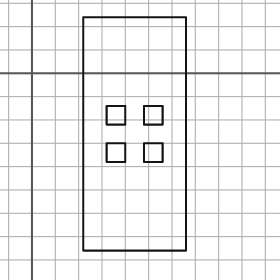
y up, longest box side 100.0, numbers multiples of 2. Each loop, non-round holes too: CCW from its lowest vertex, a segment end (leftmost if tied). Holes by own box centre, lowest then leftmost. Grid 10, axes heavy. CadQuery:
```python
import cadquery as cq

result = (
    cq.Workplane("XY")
    .moveTo(22.0, -76.0)
    .lineTo(66.0, -76.0)
    .lineTo(66.0, 24.0)
    .lineTo(22.0, 24.0)
    .close()
    .moveTo(32.0, -38.0)
    .lineTo(40.0, -38.0)
    .lineTo(40.0, -30.0)
    .lineTo(32.0, -30.0)
    .close()
    .moveTo(48.0, -38.0)
    .lineTo(56.0, -38.0)
    .lineTo(56.0, -30.0)
    .lineTo(48.0, -30.0)
    .close()
    .moveTo(32.0, -22.0)
    .lineTo(40.0, -22.0)
    .lineTo(40.0, -14.0)
    .lineTo(32.0, -14.0)
    .close()
    .moveTo(48.0, -22.0)
    .lineTo(56.0, -22.0)
    .lineTo(56.0, -14.0)
    .lineTo(48.0, -14.0)
    .close()
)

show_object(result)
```